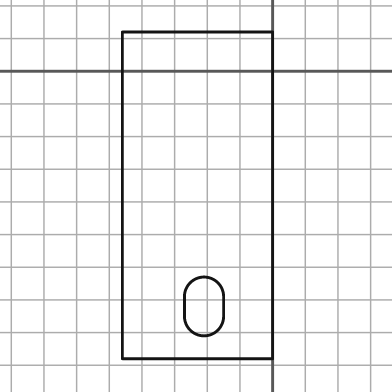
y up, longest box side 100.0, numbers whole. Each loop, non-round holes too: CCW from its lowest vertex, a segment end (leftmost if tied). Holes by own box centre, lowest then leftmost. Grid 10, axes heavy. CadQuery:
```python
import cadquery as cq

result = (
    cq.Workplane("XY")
    .moveTo(-46.0, -88.0)
    .lineTo(0.0, -88.0)
    .lineTo(0.0, 12.0)
    .lineTo(-46.0, 12.0)
    .close()
    .moveTo(-27.0, -75.0)
    .threePointArc((-21.0, -81.0), (-15.0, -75.0))
    .lineTo(-15.0, -69.0)
    .threePointArc((-21.0, -63.0), (-27.0, -69.0))
    .close()
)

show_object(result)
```